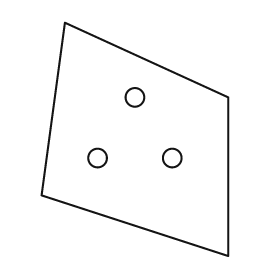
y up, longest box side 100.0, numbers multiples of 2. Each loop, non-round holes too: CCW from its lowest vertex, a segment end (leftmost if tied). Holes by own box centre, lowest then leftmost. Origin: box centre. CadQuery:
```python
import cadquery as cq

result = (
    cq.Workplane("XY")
    .moveTo(40.0, -50.0)
    .lineTo(40.0, 18.0)
    .lineTo(-30.0, 50.0)
    .lineTo(-40.0, -24.0)
    .close()
    .moveTo(-16.0, -8.0)
    .circle(4.0)
    .moveTo(16.0, -8.0)
    .circle(4.0)
    .moveTo(0.0, 18.0)
    .circle(4.0)
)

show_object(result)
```